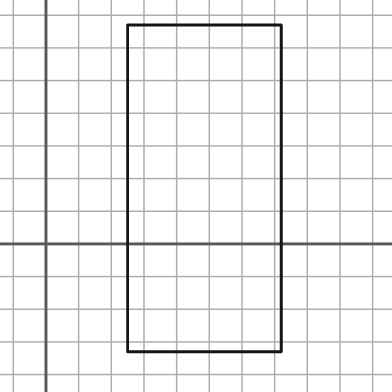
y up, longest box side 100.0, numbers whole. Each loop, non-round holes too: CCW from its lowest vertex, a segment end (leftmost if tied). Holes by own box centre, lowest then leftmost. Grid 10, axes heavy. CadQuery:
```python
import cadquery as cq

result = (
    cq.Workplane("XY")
    .moveTo(25.0, -33.0)
    .lineTo(72.0, -33.0)
    .lineTo(72.0, 67.0)
    .lineTo(25.0, 67.0)
    .close()
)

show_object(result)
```